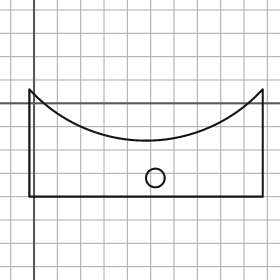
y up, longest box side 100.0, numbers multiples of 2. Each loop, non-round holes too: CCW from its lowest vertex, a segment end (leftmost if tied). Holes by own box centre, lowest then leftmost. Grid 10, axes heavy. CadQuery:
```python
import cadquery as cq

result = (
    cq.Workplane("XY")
    .moveTo(-2.0, -40.0)
    .lineTo(98.0, -40.0)
    .lineTo(98.0, 6.0)
    .threePointArc((48.0, -16.0), (-2.0, 6.0))
    .close()
    .moveTo(52.0, -32.0)
    .circle(4.0)
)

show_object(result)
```